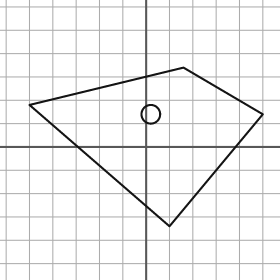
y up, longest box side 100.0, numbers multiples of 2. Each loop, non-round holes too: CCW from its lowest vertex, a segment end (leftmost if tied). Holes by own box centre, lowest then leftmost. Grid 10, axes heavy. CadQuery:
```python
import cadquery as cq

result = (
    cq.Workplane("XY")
    .moveTo(10.0, -34.0)
    .lineTo(50.0, 14.0)
    .lineTo(16.0, 34.0)
    .lineTo(-50.0, 18.0)
    .close()
    .moveTo(2.0, 14.0)
    .circle(4.0)
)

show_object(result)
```